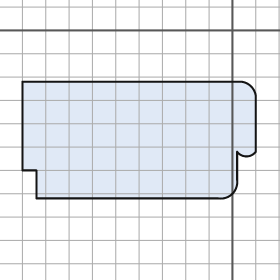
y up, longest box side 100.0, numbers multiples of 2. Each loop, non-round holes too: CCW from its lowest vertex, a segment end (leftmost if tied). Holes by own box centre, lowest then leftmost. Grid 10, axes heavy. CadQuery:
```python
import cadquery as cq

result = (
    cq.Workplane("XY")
    .moveTo(-84.0, -72.0)
    .lineTo(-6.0, -72.0)
    .threePointArc((0.0, -70.0), (2.0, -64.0))
    .lineTo(2.0, -52.0)
    .threePointArc((6.0, -54.0), (10.0, -52.0))
    .lineTo(10.0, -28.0)
    .threePointArc((8.0, -24.0), (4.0, -22.0))
    .lineTo(-90.0, -22.0)
    .lineTo(-90.0, -60.0)
    .lineTo(-84.0, -60.0)
    .close()
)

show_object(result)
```